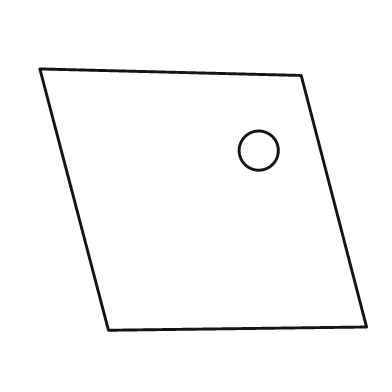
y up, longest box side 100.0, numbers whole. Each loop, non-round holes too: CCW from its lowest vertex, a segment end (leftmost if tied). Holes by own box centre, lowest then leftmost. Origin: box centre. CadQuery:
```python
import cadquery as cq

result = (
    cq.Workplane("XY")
    .moveTo(-29.0, -40.0)
    .lineTo(50.0, -39.0)
    .lineTo(30.0, 38.0)
    .lineTo(-50.0, 40.0)
    .close()
    .moveTo(17.0, 15.0)
    .circle(6.0)
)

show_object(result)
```